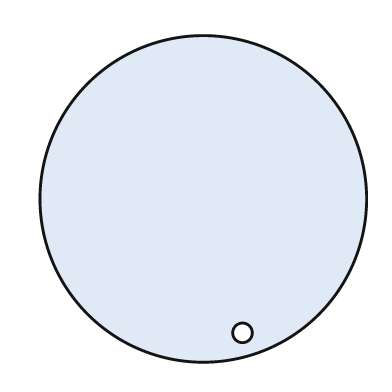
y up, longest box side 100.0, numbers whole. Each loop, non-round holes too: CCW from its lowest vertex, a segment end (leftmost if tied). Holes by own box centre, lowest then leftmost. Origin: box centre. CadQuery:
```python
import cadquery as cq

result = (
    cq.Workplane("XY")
    .moveTo(0.0, 0.0)
    .circle(50.0)
    .moveTo(12.0, -41.0)
    .circle(3.0)
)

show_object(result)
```